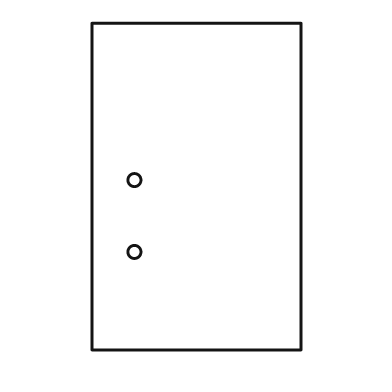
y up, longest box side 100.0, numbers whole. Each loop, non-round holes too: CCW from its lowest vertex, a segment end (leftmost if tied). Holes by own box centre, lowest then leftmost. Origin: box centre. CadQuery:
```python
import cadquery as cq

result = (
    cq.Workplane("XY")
    .moveTo(-32.0, -50.0)
    .lineTo(32.0, -50.0)
    .lineTo(32.0, 50.0)
    .lineTo(-32.0, 50.0)
    .close()
    .moveTo(-19.0, -20.0)
    .circle(2.0)
    .moveTo(-19.0, 2.0)
    .circle(2.0)
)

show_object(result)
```